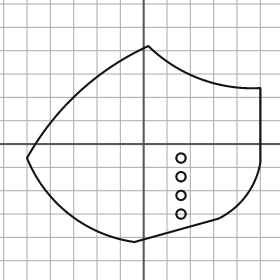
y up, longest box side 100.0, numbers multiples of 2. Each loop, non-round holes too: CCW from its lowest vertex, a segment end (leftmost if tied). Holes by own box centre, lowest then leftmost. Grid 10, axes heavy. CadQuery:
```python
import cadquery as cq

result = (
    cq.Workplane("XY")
    .moveTo(-4.0, -42.0)
    .lineTo(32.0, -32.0)
    .threePointArc((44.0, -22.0), (50.0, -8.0))
    .lineTo(50.0, 24.0)
    .threePointArc((24.0, 28.0), (2.0, 42.0))
    .threePointArc((-28.0, 22.0), (-50.0, -6.0))
    .threePointArc((-32.0, -30.0), (-4.0, -42.0))
    .close()
    .moveTo(16.0, -30.0)
    .circle(2.0)
    .moveTo(16.0, -22.0)
    .circle(2.0)
    .moveTo(16.0, -14.0)
    .circle(2.0)
    .moveTo(16.0, -6.0)
    .circle(2.0)
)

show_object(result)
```